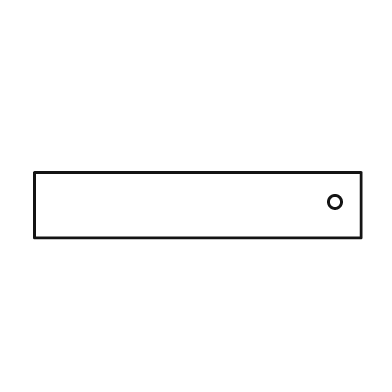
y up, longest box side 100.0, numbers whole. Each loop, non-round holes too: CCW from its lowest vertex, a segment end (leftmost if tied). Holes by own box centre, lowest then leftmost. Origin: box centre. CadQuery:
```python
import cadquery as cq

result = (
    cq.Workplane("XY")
    .moveTo(-50.0, -10.0)
    .lineTo(50.0, -10.0)
    .lineTo(50.0, 10.0)
    .lineTo(-50.0, 10.0)
    .close()
    .moveTo(42.0, 1.0)
    .circle(2.0)
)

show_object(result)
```